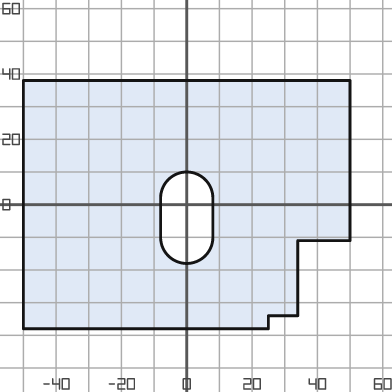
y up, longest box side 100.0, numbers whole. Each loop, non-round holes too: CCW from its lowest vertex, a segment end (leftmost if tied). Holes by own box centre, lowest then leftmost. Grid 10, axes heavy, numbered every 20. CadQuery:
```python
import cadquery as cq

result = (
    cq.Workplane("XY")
    .moveTo(-50.0, -38.0)
    .lineTo(25.0, -38.0)
    .lineTo(25.0, -34.0)
    .lineTo(34.0, -34.0)
    .lineTo(34.0, -11.0)
    .lineTo(50.0, -11.0)
    .lineTo(50.0, 38.0)
    .lineTo(-50.0, 38.0)
    .close()
    .moveTo(-8.0, -10.0)
    .threePointArc((0.0, -18.0), (8.0, -10.0))
    .lineTo(8.0, 2.0)
    .threePointArc((0.0, 10.0), (-8.0, 2.0))
    .close()
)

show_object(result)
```